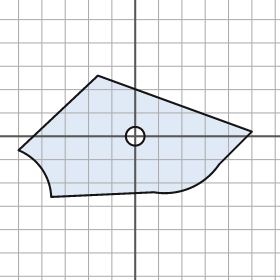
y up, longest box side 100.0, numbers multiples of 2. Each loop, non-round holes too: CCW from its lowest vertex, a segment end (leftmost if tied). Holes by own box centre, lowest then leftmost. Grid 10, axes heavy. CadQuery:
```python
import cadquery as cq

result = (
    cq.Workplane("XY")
    .moveTo(-36.0, -26.0)
    .lineTo(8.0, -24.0)
    .threePointArc((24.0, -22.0), (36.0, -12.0))
    .lineTo(50.0, 2.0)
    .lineTo(-16.0, 26.0)
    .lineTo(-50.0, -6.0)
    .threePointArc((-40.0, -14.0), (-36.0, -26.0))
    .close()
    .moveTo(0.0, 0.0)
    .circle(4.0)
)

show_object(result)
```